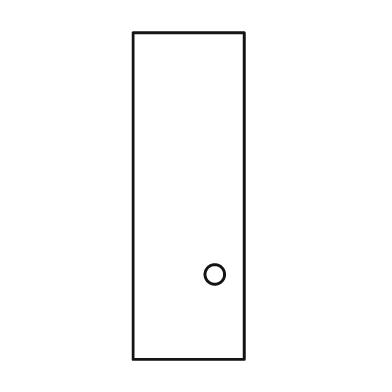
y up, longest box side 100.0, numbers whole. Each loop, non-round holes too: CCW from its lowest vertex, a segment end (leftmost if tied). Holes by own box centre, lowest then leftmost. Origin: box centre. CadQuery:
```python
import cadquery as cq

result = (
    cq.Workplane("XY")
    .moveTo(-17.0, -50.0)
    .lineTo(17.0, -50.0)
    .lineTo(17.0, 50.0)
    .lineTo(-17.0, 50.0)
    .close()
    .moveTo(8.0, -24.0)
    .circle(3.0)
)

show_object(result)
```